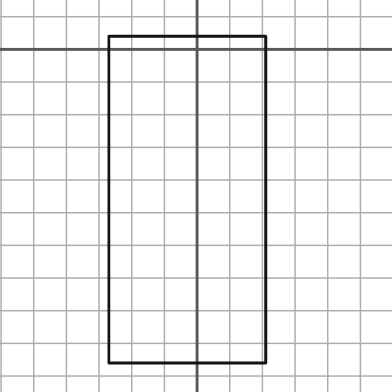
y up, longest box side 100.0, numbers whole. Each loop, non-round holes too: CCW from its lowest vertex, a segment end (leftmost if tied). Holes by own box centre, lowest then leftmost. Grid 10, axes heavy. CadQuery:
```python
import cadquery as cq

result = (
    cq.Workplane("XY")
    .moveTo(-27.0, -96.0)
    .lineTo(21.0, -96.0)
    .lineTo(21.0, 4.0)
    .lineTo(-27.0, 4.0)
    .close()
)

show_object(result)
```